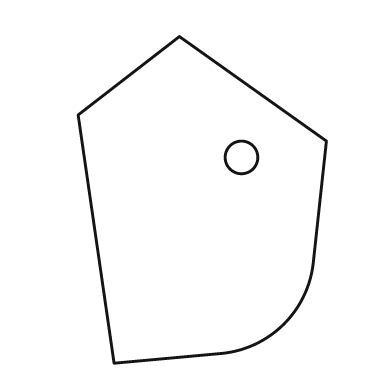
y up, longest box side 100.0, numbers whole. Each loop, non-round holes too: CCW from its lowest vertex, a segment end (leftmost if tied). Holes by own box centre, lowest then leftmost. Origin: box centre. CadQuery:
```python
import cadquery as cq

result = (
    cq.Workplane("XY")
    .moveTo(-27.0, -50.0)
    .lineTo(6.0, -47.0)
    .threePointArc((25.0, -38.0), (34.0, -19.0))
    .lineTo(38.0, 18.0)
    .lineTo(-7.0, 50.0)
    .lineTo(-38.0, 26.0)
    .close()
    .moveTo(12.0, 13.0)
    .circle(5.0)
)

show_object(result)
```